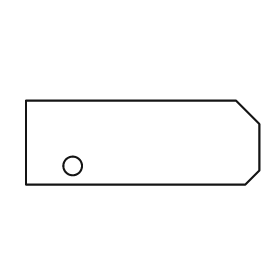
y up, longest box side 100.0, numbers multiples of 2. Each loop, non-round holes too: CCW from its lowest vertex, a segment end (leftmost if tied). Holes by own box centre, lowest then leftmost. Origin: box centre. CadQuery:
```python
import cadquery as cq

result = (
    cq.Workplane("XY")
    .moveTo(-50.0, -18.0)
    .lineTo(44.0, -18.0)
    .lineTo(50.0, -12.0)
    .lineTo(50.0, 8.0)
    .lineTo(40.0, 18.0)
    .lineTo(-50.0, 18.0)
    .close()
    .moveTo(-30.0, -10.0)
    .circle(4.0)
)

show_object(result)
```